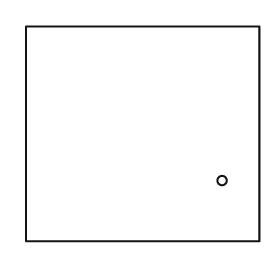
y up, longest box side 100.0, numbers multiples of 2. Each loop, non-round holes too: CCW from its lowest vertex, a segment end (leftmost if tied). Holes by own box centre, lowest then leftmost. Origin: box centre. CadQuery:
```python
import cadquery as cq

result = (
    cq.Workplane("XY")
    .moveTo(-50.0, -46.0)
    .lineTo(50.0, -46.0)
    .lineTo(50.0, 46.0)
    .lineTo(-50.0, 46.0)
    .close()
    .moveTo(34.0, -20.0)
    .circle(2.0)
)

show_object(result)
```